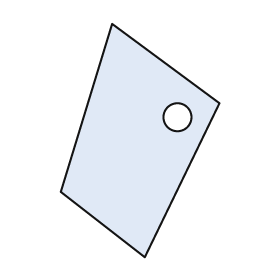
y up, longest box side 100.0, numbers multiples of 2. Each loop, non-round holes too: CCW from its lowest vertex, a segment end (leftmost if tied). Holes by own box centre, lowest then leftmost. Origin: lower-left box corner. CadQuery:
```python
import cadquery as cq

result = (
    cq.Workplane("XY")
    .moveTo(36.0, 0.0)
    .lineTo(68.0, 66.0)
    .lineTo(22.0, 100.0)
    .lineTo(0.0, 28.0)
    .close()
    .moveTo(50.0, 60.0)
    .circle(6.0)
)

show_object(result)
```